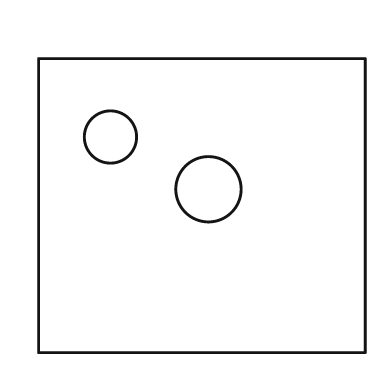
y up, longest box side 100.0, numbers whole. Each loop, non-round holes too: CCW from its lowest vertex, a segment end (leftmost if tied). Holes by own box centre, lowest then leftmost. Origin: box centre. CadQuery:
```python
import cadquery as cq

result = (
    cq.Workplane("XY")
    .moveTo(-50.0, -45.0)
    .lineTo(50.0, -45.0)
    .lineTo(50.0, 45.0)
    .lineTo(-50.0, 45.0)
    .close()
    .moveTo(2.0, 5.0)
    .circle(10.0)
    .moveTo(-28.0, 21.0)
    .circle(8.0)
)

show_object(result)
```